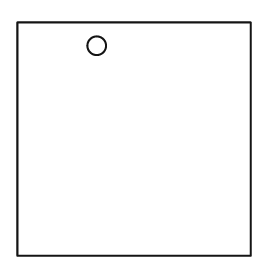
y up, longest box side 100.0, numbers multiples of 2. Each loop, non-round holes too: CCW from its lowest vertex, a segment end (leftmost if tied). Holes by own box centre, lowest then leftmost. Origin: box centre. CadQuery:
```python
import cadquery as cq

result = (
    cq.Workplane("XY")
    .moveTo(-50.0, -50.0)
    .lineTo(50.0, -50.0)
    .lineTo(50.0, 50.0)
    .lineTo(-50.0, 50.0)
    .close()
    .moveTo(-16.0, 40.0)
    .circle(4.0)
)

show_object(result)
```